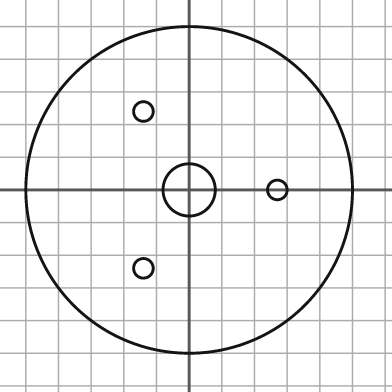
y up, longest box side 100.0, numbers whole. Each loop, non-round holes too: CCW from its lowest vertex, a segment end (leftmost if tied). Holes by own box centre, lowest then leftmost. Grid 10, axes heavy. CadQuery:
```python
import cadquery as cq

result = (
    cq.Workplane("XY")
    .moveTo(0.0, 0.0)
    .circle(50.0)
    .moveTo(-14.0, -24.0)
    .circle(3.0)
    .moveTo(0.0, 0.0)
    .circle(8.0)
    .moveTo(27.0, 0.0)
    .circle(3.0)
    .moveTo(-14.0, 24.0)
    .circle(3.0)
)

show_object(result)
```